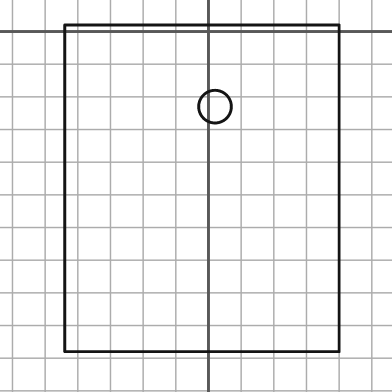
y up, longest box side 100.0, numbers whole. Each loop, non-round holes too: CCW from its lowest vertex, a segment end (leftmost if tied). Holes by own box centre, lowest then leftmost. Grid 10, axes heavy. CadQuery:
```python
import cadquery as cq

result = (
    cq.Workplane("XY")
    .moveTo(-44.0, -98.0)
    .lineTo(40.0, -98.0)
    .lineTo(40.0, 2.0)
    .lineTo(-44.0, 2.0)
    .close()
    .moveTo(2.0, -23.0)
    .circle(5.0)
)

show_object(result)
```